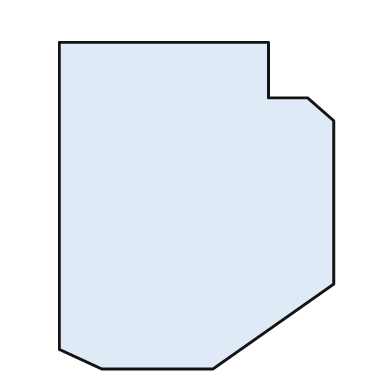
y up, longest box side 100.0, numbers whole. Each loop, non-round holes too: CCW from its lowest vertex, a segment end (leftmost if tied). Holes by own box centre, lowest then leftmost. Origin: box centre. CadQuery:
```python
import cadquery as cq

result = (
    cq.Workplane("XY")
    .moveTo(-29.0, -50.0)
    .lineTo(5.0, -50.0)
    .lineTo(42.0, -24.0)
    .lineTo(42.0, 26.0)
    .lineTo(34.0, 33.0)
    .lineTo(22.0, 33.0)
    .lineTo(22.0, 50.0)
    .lineTo(-42.0, 50.0)
    .lineTo(-42.0, -44.0)
    .close()
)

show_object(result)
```